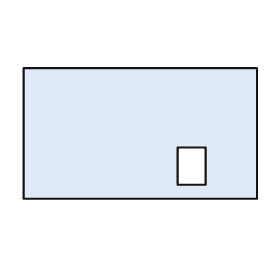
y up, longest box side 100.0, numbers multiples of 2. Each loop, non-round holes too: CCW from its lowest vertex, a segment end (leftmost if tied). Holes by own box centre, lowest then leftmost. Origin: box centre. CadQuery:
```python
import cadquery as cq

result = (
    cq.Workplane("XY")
    .moveTo(-50.0, -28.0)
    .lineTo(50.0, -28.0)
    .lineTo(50.0, 28.0)
    .lineTo(-50.0, 28.0)
    .close()
    .moveTo(16.0, -22.0)
    .lineTo(28.0, -22.0)
    .lineTo(28.0, -6.0)
    .lineTo(16.0, -6.0)
    .close()
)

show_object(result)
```